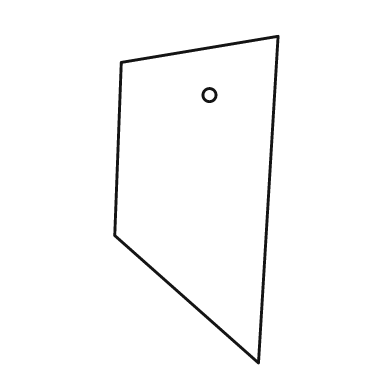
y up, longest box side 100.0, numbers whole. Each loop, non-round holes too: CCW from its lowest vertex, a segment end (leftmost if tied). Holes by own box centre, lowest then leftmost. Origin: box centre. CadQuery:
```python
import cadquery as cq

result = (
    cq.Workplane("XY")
    .moveTo(19.0, -50.0)
    .lineTo(25.0, 50.0)
    .lineTo(-23.0, 42.0)
    .lineTo(-25.0, -11.0)
    .close()
    .moveTo(4.0, 32.0)
    .circle(2.0)
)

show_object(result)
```